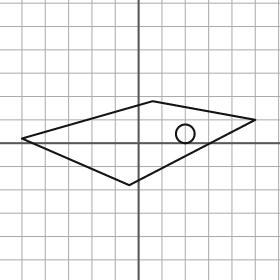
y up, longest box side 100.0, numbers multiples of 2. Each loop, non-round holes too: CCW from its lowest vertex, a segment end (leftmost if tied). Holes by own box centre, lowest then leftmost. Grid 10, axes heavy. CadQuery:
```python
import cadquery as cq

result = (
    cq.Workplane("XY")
    .moveTo(-4.0, -18.0)
    .lineTo(50.0, 10.0)
    .lineTo(6.0, 18.0)
    .lineTo(-50.0, 2.0)
    .close()
    .moveTo(20.0, 4.0)
    .circle(4.0)
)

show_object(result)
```